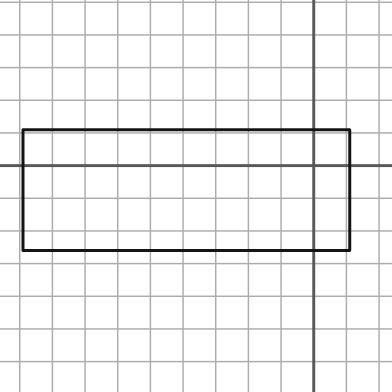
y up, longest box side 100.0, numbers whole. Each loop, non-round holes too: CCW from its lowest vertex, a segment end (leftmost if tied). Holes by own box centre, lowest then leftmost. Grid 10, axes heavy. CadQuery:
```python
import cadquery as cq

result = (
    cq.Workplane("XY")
    .moveTo(-89.0, -26.0)
    .lineTo(11.0, -26.0)
    .lineTo(11.0, 11.0)
    .lineTo(-89.0, 11.0)
    .close()
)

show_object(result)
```